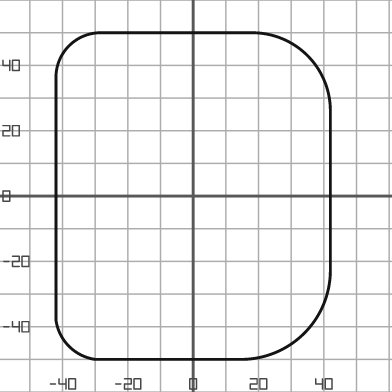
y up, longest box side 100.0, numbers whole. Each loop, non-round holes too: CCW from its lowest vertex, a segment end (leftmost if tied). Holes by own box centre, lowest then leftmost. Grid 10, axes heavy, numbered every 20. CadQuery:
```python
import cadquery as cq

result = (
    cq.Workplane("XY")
    .moveTo(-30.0, -50.0)
    .lineTo(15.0, -50.0)
    .threePointArc((34.0, -42.0), (42.0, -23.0))
    .lineTo(42.0, 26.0)
    .threePointArc((35.0, 43.0), (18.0, 50.0))
    .lineTo(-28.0, 50.0)
    .threePointArc((-38.0, 46.0), (-42.0, 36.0))
    .lineTo(-42.0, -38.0)
    .threePointArc((-38.0, -46.0), (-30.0, -50.0))
    .close()
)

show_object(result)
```